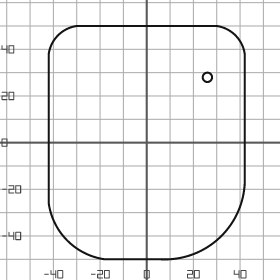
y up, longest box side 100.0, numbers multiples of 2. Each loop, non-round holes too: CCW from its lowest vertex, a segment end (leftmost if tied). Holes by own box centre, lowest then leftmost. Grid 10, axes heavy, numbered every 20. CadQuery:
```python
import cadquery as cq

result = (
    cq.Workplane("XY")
    .moveTo(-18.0, -50.0)
    .lineTo(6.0, -50.0)
    .threePointArc((32.0, -40.0), (42.0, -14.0))
    .lineTo(42.0, 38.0)
    .threePointArc((38.0, 46.0), (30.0, 50.0))
    .lineTo(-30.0, 50.0)
    .threePointArc((-38.0, 46.0), (-42.0, 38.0))
    .lineTo(-42.0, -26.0)
    .threePointArc((-34.0, -42.0), (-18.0, -50.0))
    .close()
    .moveTo(26.0, 28.0)
    .circle(2.0)
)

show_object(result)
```